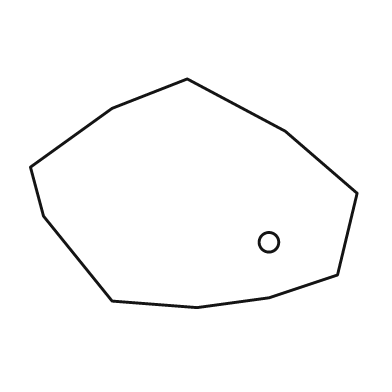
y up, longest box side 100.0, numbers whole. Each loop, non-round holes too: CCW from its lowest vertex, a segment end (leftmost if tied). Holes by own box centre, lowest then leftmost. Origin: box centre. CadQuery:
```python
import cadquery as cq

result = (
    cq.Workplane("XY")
    .moveTo(1.0, -35.0)
    .lineTo(23.0, -32.0)
    .lineTo(44.0, -25.0)
    .lineTo(50.0, 0.0)
    .lineTo(28.0, 19.0)
    .lineTo(-2.0, 35.0)
    .lineTo(-25.0, 26.0)
    .lineTo(-50.0, 8.0)
    .lineTo(-46.0, -7.0)
    .lineTo(-25.0, -33.0)
    .close()
    .moveTo(23.0, -15.0)
    .circle(3.0)
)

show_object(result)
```